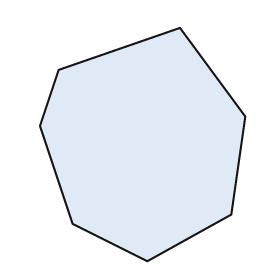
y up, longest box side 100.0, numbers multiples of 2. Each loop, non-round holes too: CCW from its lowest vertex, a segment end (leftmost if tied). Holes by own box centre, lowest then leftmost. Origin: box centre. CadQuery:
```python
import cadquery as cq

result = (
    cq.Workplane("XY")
    .moveTo(2.0, -50.0)
    .lineTo(38.0, -30.0)
    .lineTo(44.0, 12.0)
    .lineTo(16.0, 50.0)
    .lineTo(-36.0, 32.0)
    .lineTo(-44.0, 8.0)
    .lineTo(-30.0, -34.0)
    .close()
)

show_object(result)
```